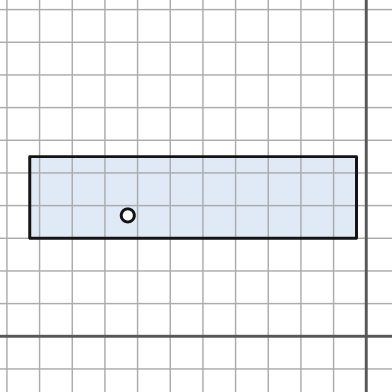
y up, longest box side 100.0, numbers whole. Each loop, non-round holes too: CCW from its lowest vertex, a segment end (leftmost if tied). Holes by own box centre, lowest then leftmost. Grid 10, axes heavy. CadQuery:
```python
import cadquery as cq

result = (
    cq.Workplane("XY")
    .moveTo(-103.0, 30.0)
    .lineTo(-3.0, 30.0)
    .lineTo(-3.0, 55.0)
    .lineTo(-103.0, 55.0)
    .close()
    .moveTo(-73.0, 37.0)
    .circle(2.0)
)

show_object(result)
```